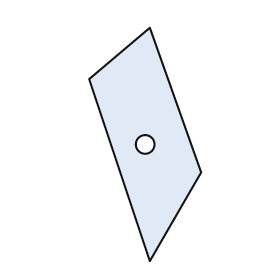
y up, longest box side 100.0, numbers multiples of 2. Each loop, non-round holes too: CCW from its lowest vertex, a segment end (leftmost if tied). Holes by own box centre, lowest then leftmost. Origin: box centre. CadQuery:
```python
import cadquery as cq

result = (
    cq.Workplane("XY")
    .moveTo(2.0, -50.0)
    .lineTo(24.0, -12.0)
    .lineTo(2.0, 50.0)
    .lineTo(-24.0, 28.0)
    .close()
    .moveTo(0.0, 0.0)
    .circle(4.0)
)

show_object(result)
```